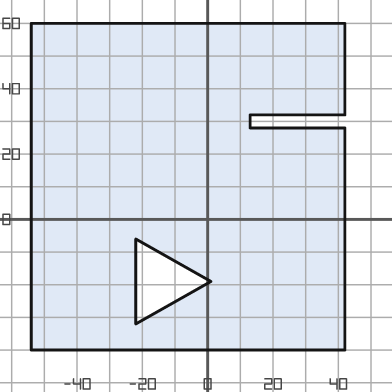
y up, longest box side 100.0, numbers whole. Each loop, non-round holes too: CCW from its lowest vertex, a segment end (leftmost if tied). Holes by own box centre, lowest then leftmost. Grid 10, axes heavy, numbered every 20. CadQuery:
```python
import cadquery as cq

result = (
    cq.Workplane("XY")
    .moveTo(-54.0, -40.0)
    .lineTo(42.0, -40.0)
    .lineTo(42.0, 28.0)
    .lineTo(13.0, 28.0)
    .lineTo(13.0, 32.0)
    .lineTo(42.0, 32.0)
    .lineTo(42.0, 60.0)
    .lineTo(-54.0, 60.0)
    .close()
    .moveTo(-22.0, -32.0)
    .lineTo(1.0, -19.0)
    .lineTo(-22.0, -6.0)
    .close()
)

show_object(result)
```